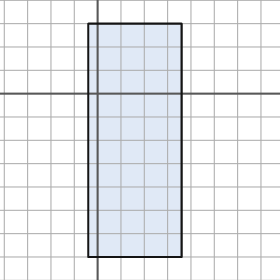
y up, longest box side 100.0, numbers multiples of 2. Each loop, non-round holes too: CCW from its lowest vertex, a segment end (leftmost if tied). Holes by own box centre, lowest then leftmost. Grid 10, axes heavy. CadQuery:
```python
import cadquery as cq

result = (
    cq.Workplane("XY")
    .moveTo(-4.0, -70.0)
    .lineTo(36.0, -70.0)
    .lineTo(36.0, 30.0)
    .lineTo(-4.0, 30.0)
    .close()
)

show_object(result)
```